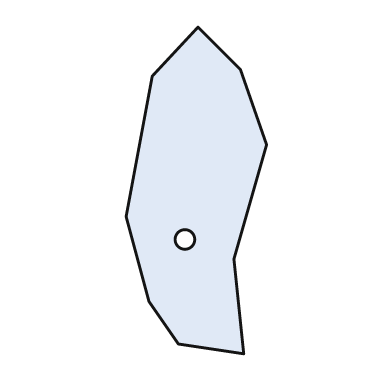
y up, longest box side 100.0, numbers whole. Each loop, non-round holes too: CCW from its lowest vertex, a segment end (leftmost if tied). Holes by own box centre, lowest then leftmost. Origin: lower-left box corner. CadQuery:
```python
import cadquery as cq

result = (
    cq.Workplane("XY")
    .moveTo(36.0, 0.0)
    .lineTo(33.0, 29.0)
    .lineTo(43.0, 64.0)
    .lineTo(35.0, 87.0)
    .lineTo(22.0, 100.0)
    .lineTo(8.0, 85.0)
    .lineTo(0.0, 42.0)
    .lineTo(7.0, 16.0)
    .lineTo(16.0, 3.0)
    .close()
    .moveTo(18.0, 35.0)
    .circle(3.0)
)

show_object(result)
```